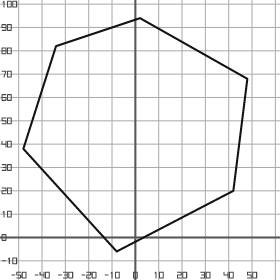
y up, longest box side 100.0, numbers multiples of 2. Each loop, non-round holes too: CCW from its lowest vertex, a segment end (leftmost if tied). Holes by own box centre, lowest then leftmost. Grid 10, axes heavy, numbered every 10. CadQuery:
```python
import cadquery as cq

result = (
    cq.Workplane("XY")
    .moveTo(-8.0, -6.0)
    .lineTo(42.0, 20.0)
    .lineTo(48.0, 68.0)
    .lineTo(2.0, 94.0)
    .lineTo(-34.0, 82.0)
    .lineTo(-48.0, 38.0)
    .close()
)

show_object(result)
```